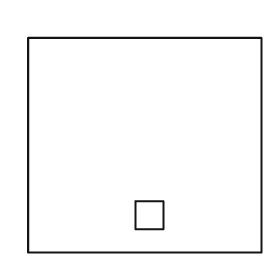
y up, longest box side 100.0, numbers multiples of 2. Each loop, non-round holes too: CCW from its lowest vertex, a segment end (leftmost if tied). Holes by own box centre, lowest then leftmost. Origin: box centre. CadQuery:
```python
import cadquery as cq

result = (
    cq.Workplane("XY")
    .moveTo(-50.0, -46.0)
    .lineTo(50.0, -46.0)
    .lineTo(50.0, 46.0)
    .lineTo(-50.0, 46.0)
    .close()
    .moveTo(-4.0, -36.0)
    .lineTo(8.0, -36.0)
    .lineTo(8.0, -24.0)
    .lineTo(-4.0, -24.0)
    .close()
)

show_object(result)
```